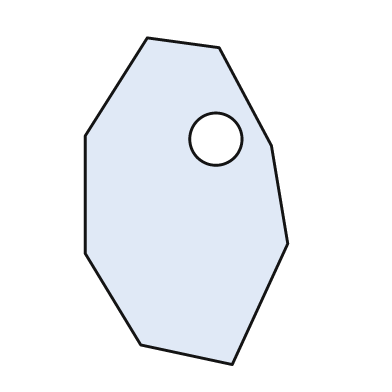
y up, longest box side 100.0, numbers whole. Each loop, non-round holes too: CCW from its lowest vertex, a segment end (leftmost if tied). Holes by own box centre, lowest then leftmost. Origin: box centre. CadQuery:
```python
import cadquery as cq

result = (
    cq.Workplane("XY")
    .moveTo(14.0, -50.0)
    .lineTo(31.0, -13.0)
    .lineTo(26.0, 17.0)
    .lineTo(10.0, 47.0)
    .lineTo(-12.0, 50.0)
    .lineTo(-31.0, 20.0)
    .lineTo(-31.0, -16.0)
    .lineTo(-14.0, -44.0)
    .close()
    .moveTo(9.0, 19.0)
    .circle(8.0)
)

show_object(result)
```